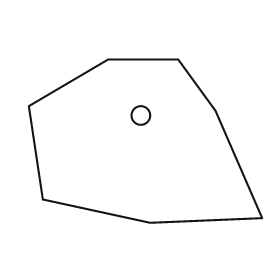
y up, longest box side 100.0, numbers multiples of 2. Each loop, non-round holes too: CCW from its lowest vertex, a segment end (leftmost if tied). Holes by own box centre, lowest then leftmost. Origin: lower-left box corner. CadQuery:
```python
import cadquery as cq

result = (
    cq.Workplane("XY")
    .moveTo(52.0, 0.0)
    .lineTo(100.0, 2.0)
    .lineTo(80.0, 48.0)
    .lineTo(64.0, 70.0)
    .lineTo(34.0, 70.0)
    .lineTo(0.0, 50.0)
    .lineTo(6.0, 10.0)
    .close()
    .moveTo(48.0, 46.0)
    .circle(4.0)
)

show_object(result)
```